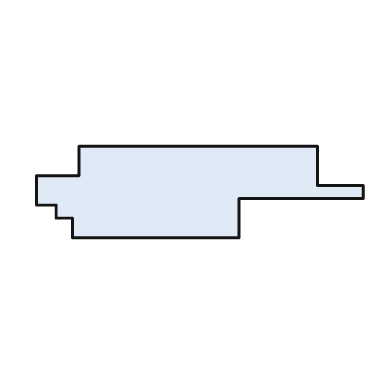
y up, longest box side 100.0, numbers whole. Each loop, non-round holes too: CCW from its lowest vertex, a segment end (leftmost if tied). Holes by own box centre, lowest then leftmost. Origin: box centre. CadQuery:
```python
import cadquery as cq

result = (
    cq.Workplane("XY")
    .moveTo(-39.0, -14.0)
    .lineTo(12.0, -14.0)
    .lineTo(12.0, -2.0)
    .lineTo(50.0, -2.0)
    .lineTo(50.0, 2.0)
    .lineTo(36.0, 2.0)
    .lineTo(36.0, 14.0)
    .lineTo(-37.0, 14.0)
    .lineTo(-37.0, 5.0)
    .lineTo(-50.0, 5.0)
    .lineTo(-50.0, -4.0)
    .lineTo(-44.0, -4.0)
    .lineTo(-44.0, -8.0)
    .lineTo(-39.0, -8.0)
    .close()
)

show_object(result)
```